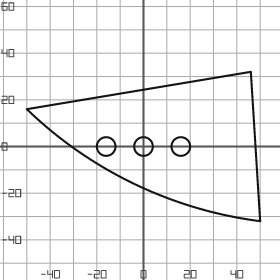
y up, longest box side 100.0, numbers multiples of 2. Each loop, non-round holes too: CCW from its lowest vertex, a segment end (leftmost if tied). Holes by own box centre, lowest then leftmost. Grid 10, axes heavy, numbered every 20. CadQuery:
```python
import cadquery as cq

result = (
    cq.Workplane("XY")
    .moveTo(50.0, -32.0)
    .lineTo(46.0, 32.0)
    .lineTo(-50.0, 16.0)
    .threePointArc((-4.0, -16.0), (50.0, -32.0))
    .close()
    .moveTo(-16.0, 0.0)
    .circle(4.0)
    .moveTo(0.0, 0.0)
    .circle(4.0)
    .moveTo(16.0, 0.0)
    .circle(4.0)
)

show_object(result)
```